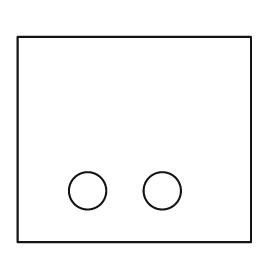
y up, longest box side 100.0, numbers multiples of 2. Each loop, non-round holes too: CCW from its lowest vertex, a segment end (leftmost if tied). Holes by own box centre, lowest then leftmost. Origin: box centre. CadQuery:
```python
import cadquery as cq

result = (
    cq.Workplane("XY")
    .moveTo(-50.0, -44.0)
    .lineTo(50.0, -44.0)
    .lineTo(50.0, 44.0)
    .lineTo(-50.0, 44.0)
    .close()
    .moveTo(-20.0, -22.0)
    .circle(8.0)
    .moveTo(12.0, -22.0)
    .circle(8.0)
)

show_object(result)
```